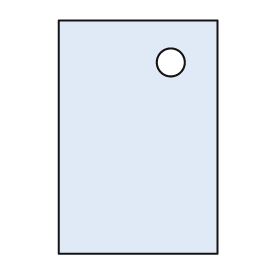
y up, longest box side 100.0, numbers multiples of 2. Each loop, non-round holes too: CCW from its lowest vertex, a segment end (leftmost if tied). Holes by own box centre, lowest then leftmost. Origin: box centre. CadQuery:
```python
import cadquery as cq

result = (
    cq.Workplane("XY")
    .moveTo(-34.0, -50.0)
    .lineTo(34.0, -50.0)
    .lineTo(34.0, 50.0)
    .lineTo(-34.0, 50.0)
    .close()
    .moveTo(14.0, 32.0)
    .circle(6.0)
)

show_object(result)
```